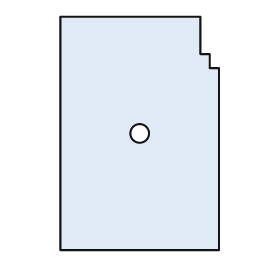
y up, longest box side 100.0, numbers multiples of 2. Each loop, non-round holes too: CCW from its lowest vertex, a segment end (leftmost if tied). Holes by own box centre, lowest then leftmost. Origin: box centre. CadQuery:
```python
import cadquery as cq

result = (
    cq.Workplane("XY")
    .moveTo(-34.0, -50.0)
    .lineTo(34.0, -50.0)
    .lineTo(34.0, 28.0)
    .lineTo(30.0, 28.0)
    .lineTo(30.0, 34.0)
    .lineTo(26.0, 34.0)
    .lineTo(26.0, 50.0)
    .lineTo(-34.0, 50.0)
    .close()
    .moveTo(0.0, 0.0)
    .circle(4.0)
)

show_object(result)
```